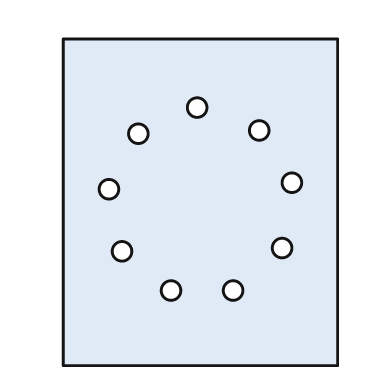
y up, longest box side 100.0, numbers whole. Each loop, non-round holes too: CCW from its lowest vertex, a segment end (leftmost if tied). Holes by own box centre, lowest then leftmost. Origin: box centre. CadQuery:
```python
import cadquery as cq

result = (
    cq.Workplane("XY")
    .moveTo(-42.0, -50.0)
    .lineTo(42.0, -50.0)
    .lineTo(42.0, 50.0)
    .lineTo(-42.0, 50.0)
    .close()
    .moveTo(-9.0, -27.0)
    .circle(3.0)
    .moveTo(10.0, -27.0)
    .circle(3.0)
    .moveTo(-24.0, -15.0)
    .circle(3.0)
    .moveTo(25.0, -14.0)
    .circle(3.0)
    .moveTo(-28.0, 4.0)
    .circle(3.0)
    .moveTo(28.0, 6.0)
    .circle(3.0)
    .moveTo(-19.0, 21.0)
    .circle(3.0)
    .moveTo(18.0, 22.0)
    .circle(3.0)
    .moveTo(-1.0, 29.0)
    .circle(3.0)
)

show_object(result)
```